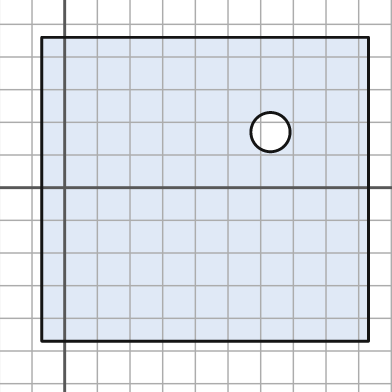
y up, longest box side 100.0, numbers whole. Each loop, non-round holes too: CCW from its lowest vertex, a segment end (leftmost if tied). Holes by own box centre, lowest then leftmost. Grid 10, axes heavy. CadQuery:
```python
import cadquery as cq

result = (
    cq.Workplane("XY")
    .moveTo(-7.0, -47.0)
    .lineTo(93.0, -47.0)
    .lineTo(93.0, 46.0)
    .lineTo(-7.0, 46.0)
    .close()
    .moveTo(63.0, 17.0)
    .circle(6.0)
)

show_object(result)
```